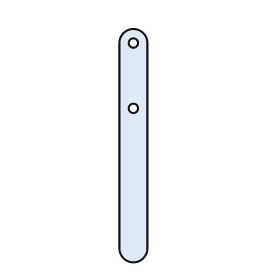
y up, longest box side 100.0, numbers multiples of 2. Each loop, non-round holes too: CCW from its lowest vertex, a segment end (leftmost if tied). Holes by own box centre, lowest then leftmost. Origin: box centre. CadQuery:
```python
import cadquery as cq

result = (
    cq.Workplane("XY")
    .moveTo(-6.0, -44.0)
    .threePointArc((0.0, -50.0), (6.0, -44.0))
    .lineTo(6.0, 44.0)
    .threePointArc((0.0, 50.0), (-6.0, 44.0))
    .close()
    .moveTo(0.0, 16.0)
    .circle(2.0)
    .moveTo(0.0, 44.0)
    .circle(2.0)
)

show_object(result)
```